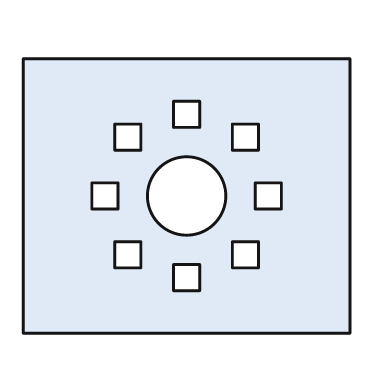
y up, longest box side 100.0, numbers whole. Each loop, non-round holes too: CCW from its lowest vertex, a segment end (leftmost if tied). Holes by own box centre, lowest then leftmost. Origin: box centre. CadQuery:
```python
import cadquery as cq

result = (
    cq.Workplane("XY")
    .moveTo(-50.0, -42.0)
    .lineTo(50.0, -42.0)
    .lineTo(50.0, 42.0)
    .lineTo(-50.0, 42.0)
    .close()
    .moveTo(-4.0, -29.0)
    .lineTo(4.0, -29.0)
    .lineTo(4.0, -21.0)
    .lineTo(-4.0, -21.0)
    .close()
    .moveTo(-22.0, -22.0)
    .lineTo(-14.0, -22.0)
    .lineTo(-14.0, -14.0)
    .lineTo(-22.0, -14.0)
    .close()
    .moveTo(14.0, -22.0)
    .lineTo(22.0, -22.0)
    .lineTo(22.0, -14.0)
    .lineTo(14.0, -14.0)
    .close()
    .moveTo(-29.0, -4.0)
    .lineTo(-21.0, -4.0)
    .lineTo(-21.0, 4.0)
    .lineTo(-29.0, 4.0)
    .close()
    .moveTo(0.0, 0.0)
    .circle(12.0)
    .moveTo(21.0, -4.0)
    .lineTo(29.0, -4.0)
    .lineTo(29.0, 4.0)
    .lineTo(21.0, 4.0)
    .close()
    .moveTo(-22.0, 14.0)
    .lineTo(-14.0, 14.0)
    .lineTo(-14.0, 22.0)
    .lineTo(-22.0, 22.0)
    .close()
    .moveTo(14.0, 14.0)
    .lineTo(22.0, 14.0)
    .lineTo(22.0, 22.0)
    .lineTo(14.0, 22.0)
    .close()
    .moveTo(-4.0, 21.0)
    .lineTo(4.0, 21.0)
    .lineTo(4.0, 29.0)
    .lineTo(-4.0, 29.0)
    .close()
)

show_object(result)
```